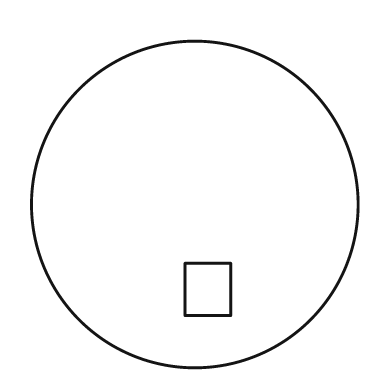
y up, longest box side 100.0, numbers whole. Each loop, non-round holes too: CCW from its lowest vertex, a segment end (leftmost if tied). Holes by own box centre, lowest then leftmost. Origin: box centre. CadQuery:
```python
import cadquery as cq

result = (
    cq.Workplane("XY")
    .moveTo(0.0, 0.0)
    .circle(50.0)
    .moveTo(-3.0, -34.0)
    .lineTo(11.0, -34.0)
    .lineTo(11.0, -18.0)
    .lineTo(-3.0, -18.0)
    .close()
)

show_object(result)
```